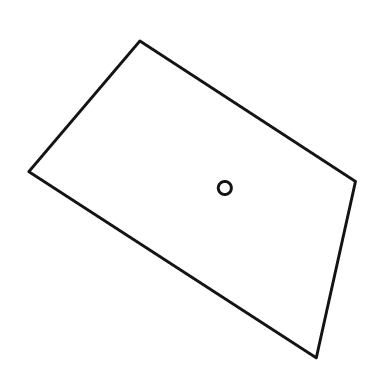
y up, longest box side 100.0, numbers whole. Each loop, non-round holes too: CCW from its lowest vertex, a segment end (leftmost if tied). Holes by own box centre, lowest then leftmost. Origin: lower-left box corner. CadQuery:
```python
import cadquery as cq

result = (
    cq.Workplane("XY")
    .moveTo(88.0, 0.0)
    .lineTo(100.0, 54.0)
    .lineTo(34.0, 97.0)
    .lineTo(0.0, 57.0)
    .close()
    .moveTo(60.0, 52.0)
    .circle(2.0)
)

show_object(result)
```